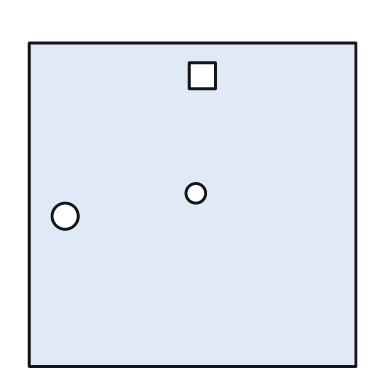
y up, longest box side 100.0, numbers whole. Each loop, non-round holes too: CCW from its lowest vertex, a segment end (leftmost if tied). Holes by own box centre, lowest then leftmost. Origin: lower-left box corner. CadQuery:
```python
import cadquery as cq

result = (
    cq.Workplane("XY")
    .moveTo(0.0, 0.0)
    .lineTo(100.0, 0.0)
    .lineTo(100.0, 99.0)
    .lineTo(0.0, 99.0)
    .close()
    .moveTo(11.0, 46.0)
    .circle(4.0)
    .moveTo(51.0, 53.0)
    .circle(3.0)
    .moveTo(49.0, 85.0)
    .lineTo(57.0, 85.0)
    .lineTo(57.0, 93.0)
    .lineTo(49.0, 93.0)
    .close()
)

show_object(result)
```